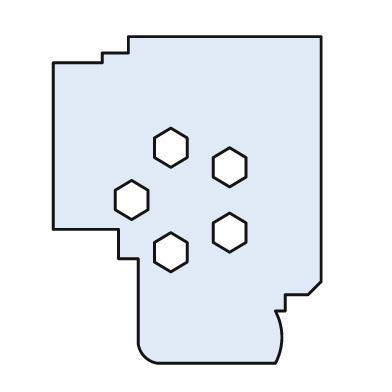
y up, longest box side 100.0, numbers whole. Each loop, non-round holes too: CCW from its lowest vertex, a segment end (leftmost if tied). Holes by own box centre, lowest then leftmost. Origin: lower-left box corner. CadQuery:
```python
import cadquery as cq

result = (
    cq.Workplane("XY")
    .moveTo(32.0, 0.0)
    .lineTo(68.0, 0.0)
    .threePointArc((70.0, 8.0), (68.0, 16.0))
    .lineTo(71.0, 16.0)
    .lineTo(71.0, 21.0)
    .lineTo(78.0, 21.0)
    .lineTo(82.0, 25.0)
    .lineTo(82.0, 100.0)
    .lineTo(23.0, 100.0)
    .lineTo(23.0, 95.0)
    .lineTo(15.0, 95.0)
    .lineTo(15.0, 92.0)
    .lineTo(0.0, 92.0)
    .lineTo(0.0, 41.0)
    .lineTo(20.0, 41.0)
    .lineTo(20.0, 32.0)
    .lineTo(26.0, 32.0)
    .lineTo(26.0, 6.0)
    .threePointArc((28.0, 2.0), (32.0, 0.0))
    .close()
    .moveTo(36.0, 28.0)
    .lineTo(41.0, 31.0)
    .lineTo(41.0, 37.0)
    .lineTo(36.0, 40.0)
    .lineTo(31.0, 37.0)
    .lineTo(31.0, 31.0)
    .close()
    .moveTo(54.0, 34.0)
    .lineTo(59.0, 37.0)
    .lineTo(59.0, 43.0)
    .lineTo(54.0, 46.0)
    .lineTo(49.0, 43.0)
    .lineTo(49.0, 37.0)
    .close()
    .moveTo(24.0, 44.0)
    .lineTo(29.0, 47.0)
    .lineTo(29.0, 53.0)
    .lineTo(24.0, 56.0)
    .lineTo(19.0, 53.0)
    .lineTo(19.0, 47.0)
    .close()
    .moveTo(54.0, 54.0)
    .lineTo(59.0, 57.0)
    .lineTo(59.0, 63.0)
    .lineTo(54.0, 66.0)
    .lineTo(49.0, 63.0)
    .lineTo(49.0, 57.0)
    .close()
    .moveTo(36.0, 60.0)
    .lineTo(41.0, 63.0)
    .lineTo(41.0, 69.0)
    .lineTo(36.0, 72.0)
    .lineTo(31.0, 69.0)
    .lineTo(31.0, 63.0)
    .close()
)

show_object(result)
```